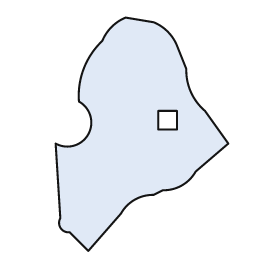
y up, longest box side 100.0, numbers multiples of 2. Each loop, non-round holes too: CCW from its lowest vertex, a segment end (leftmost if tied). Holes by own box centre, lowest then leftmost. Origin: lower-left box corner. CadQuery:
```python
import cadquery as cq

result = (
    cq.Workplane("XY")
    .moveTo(14.0, 0.0)
    .lineTo(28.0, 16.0)
    .threePointArc((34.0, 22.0), (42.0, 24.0))
    .lineTo(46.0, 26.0)
    .threePointArc((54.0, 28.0), (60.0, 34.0))
    .lineTo(74.0, 46.0)
    .lineTo(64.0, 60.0)
    .threePointArc((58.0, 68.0), (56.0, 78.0))
    .lineTo(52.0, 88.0)
    .threePointArc((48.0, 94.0), (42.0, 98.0))
    .lineTo(30.0, 100.0)
    .threePointArc((24.0, 96.0), (20.0, 90.0))
    .threePointArc((12.0, 78.0), (10.0, 64.0))
    .threePointArc((14.0, 50.0), (0.0, 46.0))
    .lineTo(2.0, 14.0)
    .threePointArc((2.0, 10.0), (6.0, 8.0))
    .close()
    .moveTo(44.0, 52.0)
    .lineTo(52.0, 52.0)
    .lineTo(52.0, 60.0)
    .lineTo(44.0, 60.0)
    .close()
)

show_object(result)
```